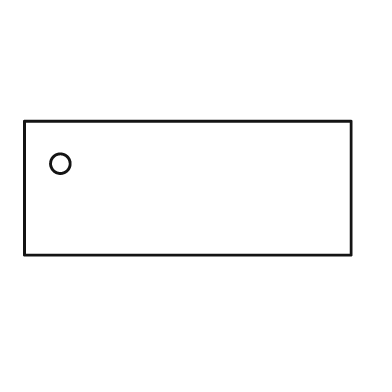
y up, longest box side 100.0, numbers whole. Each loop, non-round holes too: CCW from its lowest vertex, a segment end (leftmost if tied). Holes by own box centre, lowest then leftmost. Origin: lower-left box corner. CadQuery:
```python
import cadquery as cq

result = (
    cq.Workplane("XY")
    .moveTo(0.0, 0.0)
    .lineTo(100.0, 0.0)
    .lineTo(100.0, 41.0)
    .lineTo(0.0, 41.0)
    .close()
    .moveTo(11.0, 28.0)
    .circle(3.0)
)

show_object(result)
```